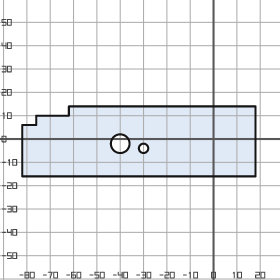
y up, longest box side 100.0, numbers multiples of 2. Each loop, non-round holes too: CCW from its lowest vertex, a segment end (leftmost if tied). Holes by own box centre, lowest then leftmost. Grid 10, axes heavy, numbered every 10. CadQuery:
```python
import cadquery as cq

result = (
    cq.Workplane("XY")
    .moveTo(-82.0, -16.0)
    .lineTo(18.0, -16.0)
    .lineTo(18.0, 14.0)
    .lineTo(-62.0, 14.0)
    .lineTo(-62.0, 10.0)
    .lineTo(-76.0, 10.0)
    .lineTo(-76.0, 6.0)
    .lineTo(-82.0, 6.0)
    .close()
    .moveTo(-30.0, -4.0)
    .circle(2.0)
    .moveTo(-40.0, -2.0)
    .circle(4.0)
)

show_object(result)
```